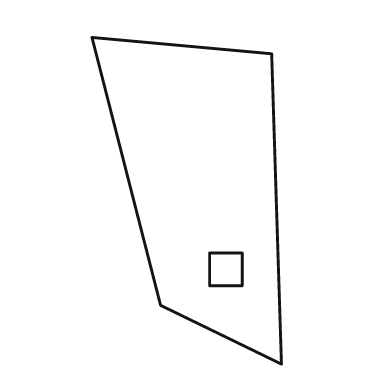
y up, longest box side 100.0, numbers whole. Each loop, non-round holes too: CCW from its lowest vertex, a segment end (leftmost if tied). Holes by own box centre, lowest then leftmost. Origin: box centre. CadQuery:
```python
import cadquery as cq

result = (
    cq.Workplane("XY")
    .moveTo(29.0, -50.0)
    .lineTo(26.0, 45.0)
    .lineTo(-29.0, 50.0)
    .lineTo(-8.0, -32.0)
    .close()
    .moveTo(7.0, -26.0)
    .lineTo(17.0, -26.0)
    .lineTo(17.0, -16.0)
    .lineTo(7.0, -16.0)
    .close()
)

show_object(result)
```